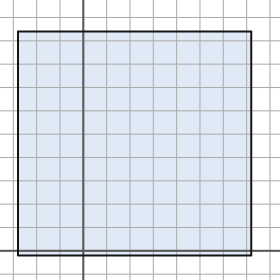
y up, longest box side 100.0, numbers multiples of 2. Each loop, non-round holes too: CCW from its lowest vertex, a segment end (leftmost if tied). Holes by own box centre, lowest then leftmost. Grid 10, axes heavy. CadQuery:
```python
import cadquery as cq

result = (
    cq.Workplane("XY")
    .moveTo(-28.0, -2.0)
    .lineTo(72.0, -2.0)
    .lineTo(72.0, 94.0)
    .lineTo(-28.0, 94.0)
    .close()
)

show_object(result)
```